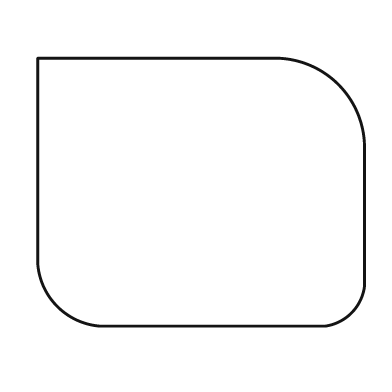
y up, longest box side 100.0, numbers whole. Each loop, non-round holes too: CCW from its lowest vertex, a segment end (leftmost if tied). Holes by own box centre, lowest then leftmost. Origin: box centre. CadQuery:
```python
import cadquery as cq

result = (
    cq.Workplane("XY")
    .moveTo(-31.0, -41.0)
    .lineTo(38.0, -41.0)
    .threePointArc((46.0, -37.0), (50.0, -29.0))
    .lineTo(50.0, 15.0)
    .threePointArc((42.0, 33.0), (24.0, 41.0))
    .lineTo(-50.0, 41.0)
    .lineTo(-50.0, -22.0)
    .threePointArc((-44.0, -35.0), (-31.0, -41.0))
    .close()
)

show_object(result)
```